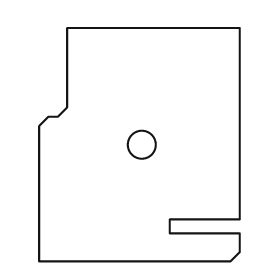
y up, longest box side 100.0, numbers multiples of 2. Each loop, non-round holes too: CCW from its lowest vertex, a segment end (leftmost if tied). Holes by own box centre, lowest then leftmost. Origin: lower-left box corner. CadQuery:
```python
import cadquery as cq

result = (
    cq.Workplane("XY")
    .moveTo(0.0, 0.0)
    .lineTo(82.0, 0.0)
    .lineTo(86.0, 4.0)
    .lineTo(86.0, 12.0)
    .lineTo(56.0, 12.0)
    .lineTo(56.0, 18.0)
    .lineTo(86.0, 18.0)
    .lineTo(86.0, 100.0)
    .lineTo(12.0, 100.0)
    .lineTo(12.0, 66.0)
    .lineTo(8.0, 62.0)
    .lineTo(4.0, 62.0)
    .lineTo(0.0, 58.0)
    .close()
    .moveTo(44.0, 50.0)
    .circle(6.0)
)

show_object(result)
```